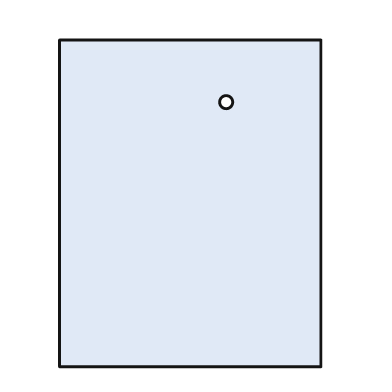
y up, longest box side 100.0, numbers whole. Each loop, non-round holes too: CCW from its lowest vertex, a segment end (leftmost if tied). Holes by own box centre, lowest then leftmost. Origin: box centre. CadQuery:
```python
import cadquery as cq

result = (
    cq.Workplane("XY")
    .moveTo(-40.0, -50.0)
    .lineTo(40.0, -50.0)
    .lineTo(40.0, 50.0)
    .lineTo(-40.0, 50.0)
    .close()
    .moveTo(11.0, 31.0)
    .circle(2.0)
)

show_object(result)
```